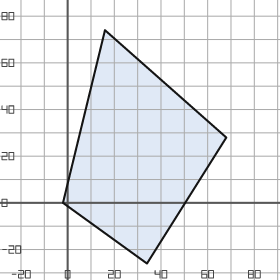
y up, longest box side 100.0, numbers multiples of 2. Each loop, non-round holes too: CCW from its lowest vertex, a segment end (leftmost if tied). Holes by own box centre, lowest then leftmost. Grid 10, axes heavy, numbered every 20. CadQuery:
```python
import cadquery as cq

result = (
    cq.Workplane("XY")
    .moveTo(34.0, -26.0)
    .lineTo(68.0, 28.0)
    .lineTo(16.0, 74.0)
    .lineTo(-2.0, 0.0)
    .close()
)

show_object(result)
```